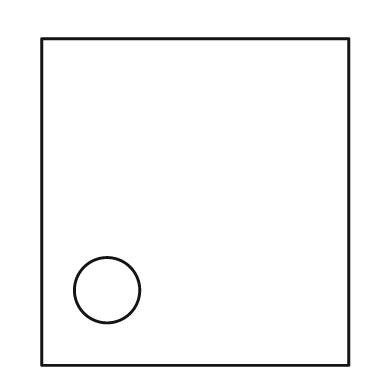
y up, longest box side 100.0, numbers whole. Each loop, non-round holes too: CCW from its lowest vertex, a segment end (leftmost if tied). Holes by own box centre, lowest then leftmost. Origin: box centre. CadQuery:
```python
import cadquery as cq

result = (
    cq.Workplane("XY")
    .moveTo(-47.0, -50.0)
    .lineTo(47.0, -50.0)
    .lineTo(47.0, 50.0)
    .lineTo(-47.0, 50.0)
    .close()
    .moveTo(-27.0, -27.0)
    .circle(10.0)
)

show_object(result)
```